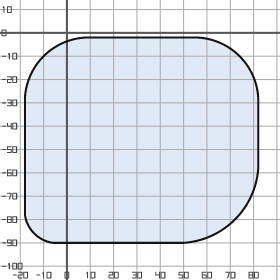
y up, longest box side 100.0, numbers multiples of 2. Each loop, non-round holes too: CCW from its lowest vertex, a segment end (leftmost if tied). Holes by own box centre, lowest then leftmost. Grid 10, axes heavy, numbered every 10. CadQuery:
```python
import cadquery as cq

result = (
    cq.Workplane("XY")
    .moveTo(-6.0, -90.0)
    .lineTo(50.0, -90.0)
    .threePointArc((72.0, -80.0), (82.0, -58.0))
    .lineTo(82.0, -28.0)
    .threePointArc((74.0, -10.0), (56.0, -2.0))
    .lineTo(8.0, -2.0)
    .threePointArc((-10.0, -10.0), (-18.0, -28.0))
    .lineTo(-18.0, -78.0)
    .threePointArc((-14.0, -86.0), (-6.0, -90.0))
    .close()
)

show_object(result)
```